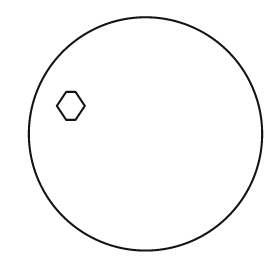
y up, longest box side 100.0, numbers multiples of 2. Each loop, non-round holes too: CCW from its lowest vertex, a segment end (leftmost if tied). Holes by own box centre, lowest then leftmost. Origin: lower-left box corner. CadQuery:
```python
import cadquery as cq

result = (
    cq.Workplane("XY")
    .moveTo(50.0, 50.0)
    .circle(50.0)
    .moveTo(16.0, 56.0)
    .lineTo(20.0, 56.0)
    .lineTo(24.0, 62.0)
    .lineTo(20.0, 68.0)
    .lineTo(16.0, 68.0)
    .lineTo(12.0, 62.0)
    .close()
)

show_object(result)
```